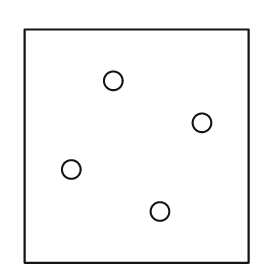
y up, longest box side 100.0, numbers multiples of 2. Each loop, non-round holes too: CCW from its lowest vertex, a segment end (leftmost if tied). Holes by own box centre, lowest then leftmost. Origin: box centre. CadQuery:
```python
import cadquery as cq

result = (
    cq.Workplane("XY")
    .moveTo(-48.0, -50.0)
    .lineTo(48.0, -50.0)
    .lineTo(48.0, 50.0)
    .lineTo(-48.0, 50.0)
    .close()
    .moveTo(10.0, -28.0)
    .circle(4.0)
    .moveTo(-28.0, -10.0)
    .circle(4.0)
    .moveTo(28.0, 10.0)
    .circle(4.0)
    .moveTo(-10.0, 28.0)
    .circle(4.0)
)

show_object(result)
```